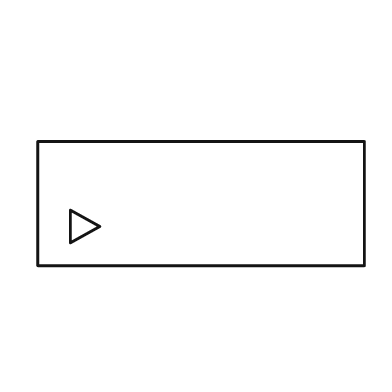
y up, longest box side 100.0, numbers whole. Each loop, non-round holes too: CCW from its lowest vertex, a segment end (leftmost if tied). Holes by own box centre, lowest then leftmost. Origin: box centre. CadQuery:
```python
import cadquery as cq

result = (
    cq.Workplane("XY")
    .moveTo(-50.0, -19.0)
    .lineTo(50.0, -19.0)
    .lineTo(50.0, 19.0)
    .lineTo(-50.0, 19.0)
    .close()
    .moveTo(-40.0, -12.0)
    .lineTo(-31.0, -7.0)
    .lineTo(-40.0, -2.0)
    .close()
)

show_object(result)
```